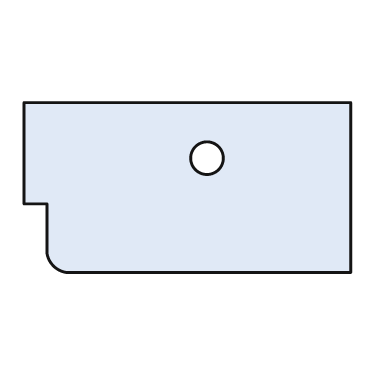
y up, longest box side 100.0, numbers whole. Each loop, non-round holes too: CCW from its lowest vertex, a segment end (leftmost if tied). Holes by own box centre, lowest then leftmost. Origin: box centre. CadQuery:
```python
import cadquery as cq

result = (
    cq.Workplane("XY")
    .moveTo(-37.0, -26.0)
    .lineTo(50.0, -26.0)
    .lineTo(50.0, 26.0)
    .lineTo(-50.0, 26.0)
    .lineTo(-50.0, -5.0)
    .lineTo(-43.0, -5.0)
    .lineTo(-43.0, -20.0)
    .threePointArc((-41.0, -24.0), (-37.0, -26.0))
    .close()
    .moveTo(6.0, 9.0)
    .circle(5.0)
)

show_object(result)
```